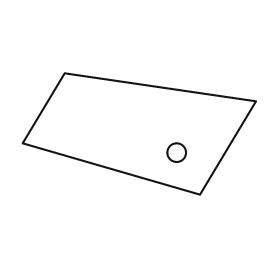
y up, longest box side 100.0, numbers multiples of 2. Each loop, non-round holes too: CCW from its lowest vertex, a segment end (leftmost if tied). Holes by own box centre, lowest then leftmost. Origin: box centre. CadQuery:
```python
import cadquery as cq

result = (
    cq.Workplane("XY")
    .moveTo(26.0, -26.0)
    .lineTo(50.0, 14.0)
    .lineTo(-32.0, 26.0)
    .lineTo(-50.0, -4.0)
    .close()
    .moveTo(16.0, -8.0)
    .circle(4.0)
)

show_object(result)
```